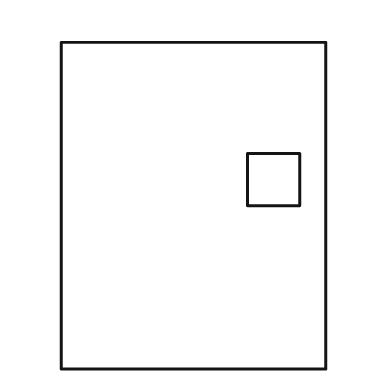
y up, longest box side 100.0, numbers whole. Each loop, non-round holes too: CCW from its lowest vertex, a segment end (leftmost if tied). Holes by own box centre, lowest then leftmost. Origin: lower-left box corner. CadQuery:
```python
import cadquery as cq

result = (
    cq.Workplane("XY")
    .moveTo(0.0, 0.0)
    .lineTo(81.0, 0.0)
    .lineTo(81.0, 100.0)
    .lineTo(0.0, 100.0)
    .close()
    .moveTo(57.0, 50.0)
    .lineTo(73.0, 50.0)
    .lineTo(73.0, 66.0)
    .lineTo(57.0, 66.0)
    .close()
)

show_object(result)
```